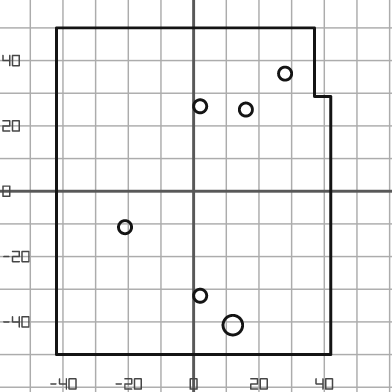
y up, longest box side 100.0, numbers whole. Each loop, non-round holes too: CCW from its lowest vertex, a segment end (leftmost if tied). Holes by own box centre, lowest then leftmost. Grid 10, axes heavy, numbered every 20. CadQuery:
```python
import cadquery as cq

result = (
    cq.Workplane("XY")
    .moveTo(-42.0, -50.0)
    .lineTo(42.0, -50.0)
    .lineTo(42.0, 29.0)
    .lineTo(37.0, 29.0)
    .lineTo(37.0, 50.0)
    .lineTo(-42.0, 50.0)
    .close()
    .moveTo(12.0, -41.0)
    .circle(3.0)
    .moveTo(2.0, -32.0)
    .circle(2.0)
    .moveTo(-21.0, -11.0)
    .circle(2.0)
    .moveTo(16.0, 25.0)
    .circle(2.0)
    .moveTo(2.0, 26.0)
    .circle(2.0)
    .moveTo(28.0, 36.0)
    .circle(2.0)
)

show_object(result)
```